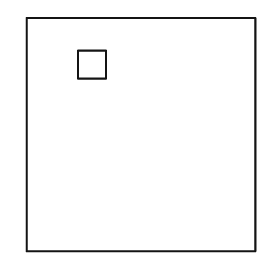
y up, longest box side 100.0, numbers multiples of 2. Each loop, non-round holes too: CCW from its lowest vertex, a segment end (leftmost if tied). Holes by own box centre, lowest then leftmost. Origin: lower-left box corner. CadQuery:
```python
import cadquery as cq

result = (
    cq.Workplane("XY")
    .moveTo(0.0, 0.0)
    .lineTo(98.0, 0.0)
    .lineTo(98.0, 100.0)
    .lineTo(0.0, 100.0)
    .close()
    .moveTo(22.0, 74.0)
    .lineTo(34.0, 74.0)
    .lineTo(34.0, 86.0)
    .lineTo(22.0, 86.0)
    .close()
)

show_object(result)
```